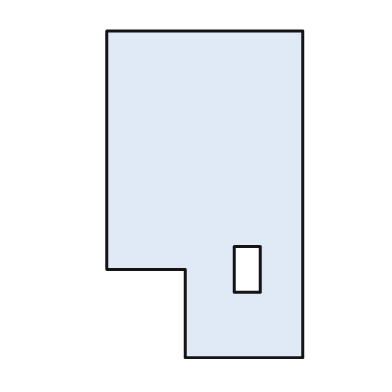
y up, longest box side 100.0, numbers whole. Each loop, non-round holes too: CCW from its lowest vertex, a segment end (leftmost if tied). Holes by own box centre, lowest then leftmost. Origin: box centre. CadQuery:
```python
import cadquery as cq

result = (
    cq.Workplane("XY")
    .moveTo(-6.0, -50.0)
    .lineTo(30.0, -50.0)
    .lineTo(30.0, 50.0)
    .lineTo(-30.0, 50.0)
    .lineTo(-30.0, -23.0)
    .lineTo(-6.0, -23.0)
    .close()
    .moveTo(9.0, -30.0)
    .lineTo(17.0, -30.0)
    .lineTo(17.0, -16.0)
    .lineTo(9.0, -16.0)
    .close()
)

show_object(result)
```